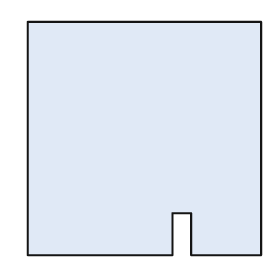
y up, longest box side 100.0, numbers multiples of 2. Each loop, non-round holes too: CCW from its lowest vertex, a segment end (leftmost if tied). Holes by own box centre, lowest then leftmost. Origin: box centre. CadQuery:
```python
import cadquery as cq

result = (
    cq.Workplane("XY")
    .moveTo(-50.0, -50.0)
    .lineTo(12.0, -50.0)
    .lineTo(12.0, -32.0)
    .lineTo(20.0, -32.0)
    .lineTo(20.0, -50.0)
    .lineTo(50.0, -50.0)
    .lineTo(50.0, 50.0)
    .lineTo(-50.0, 50.0)
    .close()
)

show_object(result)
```